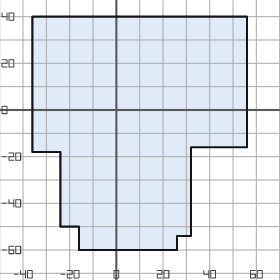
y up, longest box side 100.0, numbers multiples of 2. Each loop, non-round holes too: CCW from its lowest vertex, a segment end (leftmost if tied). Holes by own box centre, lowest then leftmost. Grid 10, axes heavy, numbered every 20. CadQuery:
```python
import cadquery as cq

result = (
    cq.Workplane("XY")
    .moveTo(-16.0, -60.0)
    .lineTo(26.0, -60.0)
    .lineTo(26.0, -54.0)
    .lineTo(32.0, -54.0)
    .lineTo(32.0, -16.0)
    .lineTo(56.0, -16.0)
    .lineTo(56.0, 40.0)
    .lineTo(-36.0, 40.0)
    .lineTo(-36.0, -18.0)
    .lineTo(-24.0, -18.0)
    .lineTo(-24.0, -50.0)
    .lineTo(-16.0, -50.0)
    .close()
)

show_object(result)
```